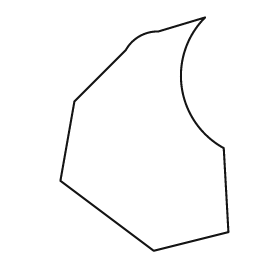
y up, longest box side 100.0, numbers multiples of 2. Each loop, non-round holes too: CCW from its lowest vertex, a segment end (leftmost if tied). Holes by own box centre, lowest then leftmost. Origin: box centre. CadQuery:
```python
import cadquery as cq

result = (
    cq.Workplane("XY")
    .moveTo(4.0, -50.0)
    .lineTo(36.0, -42.0)
    .lineTo(34.0, -6.0)
    .threePointArc((16.0, 20.0), (26.0, 50.0))
    .lineTo(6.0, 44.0)
    .threePointArc((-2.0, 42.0), (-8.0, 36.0))
    .lineTo(-30.0, 14.0)
    .lineTo(-36.0, -20.0)
    .close()
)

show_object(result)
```